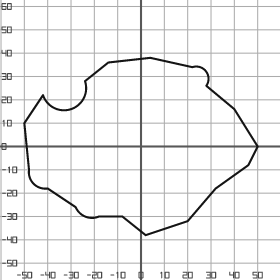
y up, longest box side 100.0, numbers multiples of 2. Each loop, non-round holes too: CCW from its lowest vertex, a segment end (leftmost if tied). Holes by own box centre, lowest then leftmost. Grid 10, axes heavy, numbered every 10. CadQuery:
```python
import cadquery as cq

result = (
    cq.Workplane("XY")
    .moveTo(2.0, -38.0)
    .lineTo(20.0, -32.0)
    .lineTo(32.0, -18.0)
    .lineTo(46.0, -8.0)
    .lineTo(50.0, 0.0)
    .lineTo(40.0, 16.0)
    .lineTo(28.0, 26.0)
    .threePointArc((28.0, 32.0), (22.0, 34.0))
    .lineTo(4.0, 38.0)
    .lineTo(-14.0, 36.0)
    .lineTo(-24.0, 28.0)
    .threePointArc((-30.0, 16.0), (-42.0, 22.0))
    .lineTo(-50.0, 10.0)
    .lineTo(-48.0, -10.0)
    .threePointArc((-46.0, -16.0), (-40.0, -18.0))
    .lineTo(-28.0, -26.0)
    .threePointArc((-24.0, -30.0), (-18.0, -30.0))
    .lineTo(-8.0, -30.0)
    .close()
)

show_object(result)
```